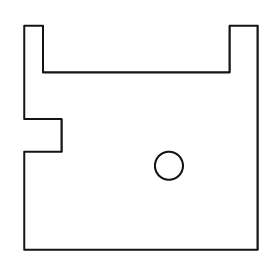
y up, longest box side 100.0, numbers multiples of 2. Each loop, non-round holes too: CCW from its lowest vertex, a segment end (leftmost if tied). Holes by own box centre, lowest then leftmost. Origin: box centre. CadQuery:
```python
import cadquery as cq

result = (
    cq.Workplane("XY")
    .moveTo(-50.0, -48.0)
    .lineTo(50.0, -48.0)
    .lineTo(50.0, 48.0)
    .lineTo(38.0, 48.0)
    .lineTo(38.0, 28.0)
    .lineTo(-42.0, 28.0)
    .lineTo(-42.0, 48.0)
    .lineTo(-50.0, 48.0)
    .lineTo(-50.0, 8.0)
    .lineTo(-34.0, 8.0)
    .lineTo(-34.0, -6.0)
    .lineTo(-50.0, -6.0)
    .close()
    .moveTo(12.0, -12.0)
    .circle(6.0)
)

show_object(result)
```